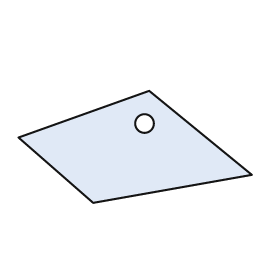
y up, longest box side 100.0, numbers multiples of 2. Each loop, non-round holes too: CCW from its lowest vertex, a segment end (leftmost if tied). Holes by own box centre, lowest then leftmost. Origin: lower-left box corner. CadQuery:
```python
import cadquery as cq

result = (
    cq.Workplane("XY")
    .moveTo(32.0, 0.0)
    .lineTo(100.0, 12.0)
    .lineTo(56.0, 48.0)
    .lineTo(0.0, 28.0)
    .close()
    .moveTo(54.0, 34.0)
    .circle(4.0)
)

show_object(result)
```